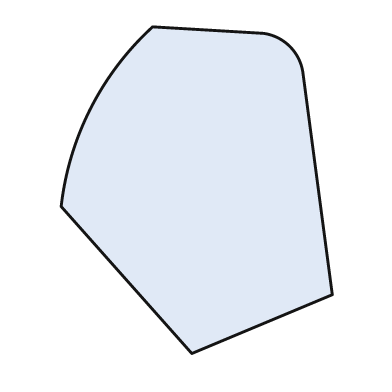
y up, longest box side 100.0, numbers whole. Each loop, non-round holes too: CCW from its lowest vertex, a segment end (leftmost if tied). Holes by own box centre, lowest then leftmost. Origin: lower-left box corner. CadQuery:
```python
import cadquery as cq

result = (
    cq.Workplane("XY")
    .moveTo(40.0, 0.0)
    .lineTo(83.0, 18.0)
    .lineTo(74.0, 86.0)
    .threePointArc((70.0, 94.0), (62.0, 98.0))
    .lineTo(28.0, 100.0)
    .threePointArc((9.0, 75.0), (0.0, 45.0))
    .close()
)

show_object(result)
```